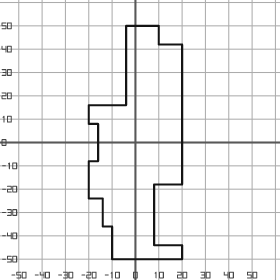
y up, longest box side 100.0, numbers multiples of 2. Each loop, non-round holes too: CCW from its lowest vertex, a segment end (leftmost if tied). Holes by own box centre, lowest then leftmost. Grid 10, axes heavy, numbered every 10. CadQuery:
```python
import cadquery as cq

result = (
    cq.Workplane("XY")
    .moveTo(-10.0, -50.0)
    .lineTo(20.0, -50.0)
    .lineTo(20.0, -44.0)
    .lineTo(8.0, -44.0)
    .lineTo(8.0, -18.0)
    .lineTo(20.0, -18.0)
    .lineTo(20.0, 42.0)
    .lineTo(10.0, 42.0)
    .lineTo(10.0, 50.0)
    .lineTo(-4.0, 50.0)
    .lineTo(-4.0, 16.0)
    .lineTo(-20.0, 16.0)
    .lineTo(-20.0, 8.0)
    .lineTo(-16.0, 8.0)
    .lineTo(-16.0, -8.0)
    .lineTo(-20.0, -8.0)
    .lineTo(-20.0, -24.0)
    .lineTo(-14.0, -24.0)
    .lineTo(-14.0, -36.0)
    .lineTo(-10.0, -36.0)
    .close()
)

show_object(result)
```